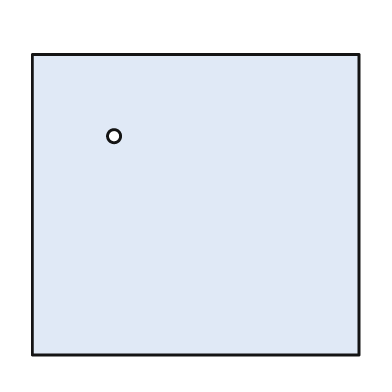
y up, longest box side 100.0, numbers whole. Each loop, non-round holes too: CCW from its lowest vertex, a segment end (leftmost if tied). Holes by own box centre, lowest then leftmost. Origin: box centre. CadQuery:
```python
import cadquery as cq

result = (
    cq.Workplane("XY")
    .moveTo(-50.0, -46.0)
    .lineTo(50.0, -46.0)
    .lineTo(50.0, 46.0)
    .lineTo(-50.0, 46.0)
    .close()
    .moveTo(-25.0, 21.0)
    .circle(2.0)
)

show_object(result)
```